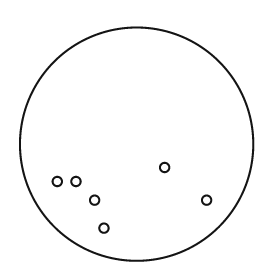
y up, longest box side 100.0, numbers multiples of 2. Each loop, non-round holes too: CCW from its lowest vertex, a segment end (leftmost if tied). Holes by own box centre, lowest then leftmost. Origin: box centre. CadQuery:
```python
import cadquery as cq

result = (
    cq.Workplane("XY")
    .moveTo(0.0, 0.0)
    .circle(50.0)
    .moveTo(-14.0, -36.0)
    .circle(2.0)
    .moveTo(-18.0, -24.0)
    .circle(2.0)
    .moveTo(30.0, -24.0)
    .circle(2.0)
    .moveTo(-34.0, -16.0)
    .circle(2.0)
    .moveTo(-26.0, -16.0)
    .circle(2.0)
    .moveTo(12.0, -10.0)
    .circle(2.0)
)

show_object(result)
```